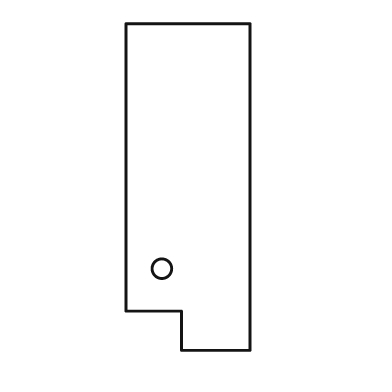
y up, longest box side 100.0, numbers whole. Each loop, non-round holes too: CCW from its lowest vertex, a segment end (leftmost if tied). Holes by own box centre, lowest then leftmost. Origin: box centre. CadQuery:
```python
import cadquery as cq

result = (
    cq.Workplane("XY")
    .moveTo(-2.0, -50.0)
    .lineTo(19.0, -50.0)
    .lineTo(19.0, 50.0)
    .lineTo(-19.0, 50.0)
    .lineTo(-19.0, -38.0)
    .lineTo(-2.0, -38.0)
    .close()
    .moveTo(-8.0, -25.0)
    .circle(3.0)
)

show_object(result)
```